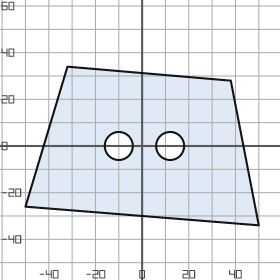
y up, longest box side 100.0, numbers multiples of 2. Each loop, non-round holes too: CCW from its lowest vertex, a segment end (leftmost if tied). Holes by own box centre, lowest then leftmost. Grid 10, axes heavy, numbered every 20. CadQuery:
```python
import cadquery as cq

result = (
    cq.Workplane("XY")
    .moveTo(50.0, -34.0)
    .lineTo(38.0, 28.0)
    .lineTo(-32.0, 34.0)
    .lineTo(-50.0, -26.0)
    .close()
    .moveTo(-10.0, 0.0)
    .circle(6.0)
    .moveTo(12.0, 0.0)
    .circle(6.0)
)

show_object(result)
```